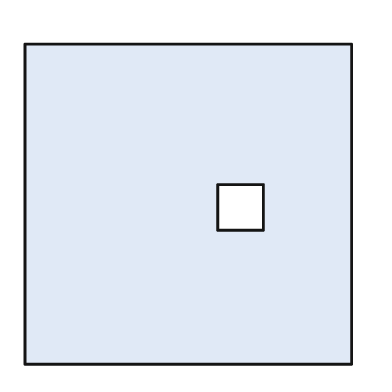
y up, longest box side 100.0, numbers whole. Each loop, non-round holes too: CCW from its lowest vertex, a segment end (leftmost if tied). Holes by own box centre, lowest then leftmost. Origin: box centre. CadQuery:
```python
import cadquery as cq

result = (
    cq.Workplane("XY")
    .moveTo(-50.0, -49.0)
    .lineTo(50.0, -49.0)
    .lineTo(50.0, 49.0)
    .lineTo(-50.0, 49.0)
    .close()
    .moveTo(9.0, -8.0)
    .lineTo(23.0, -8.0)
    .lineTo(23.0, 6.0)
    .lineTo(9.0, 6.0)
    .close()
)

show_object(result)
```